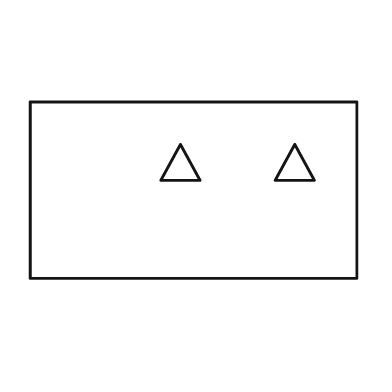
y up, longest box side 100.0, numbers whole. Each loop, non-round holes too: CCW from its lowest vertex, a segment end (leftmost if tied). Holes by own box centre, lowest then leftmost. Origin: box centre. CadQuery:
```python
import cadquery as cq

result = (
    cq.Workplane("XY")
    .moveTo(-50.0, -27.0)
    .lineTo(50.0, -27.0)
    .lineTo(50.0, 27.0)
    .lineTo(-50.0, 27.0)
    .close()
    .moveTo(-10.0, 3.0)
    .lineTo(2.0, 3.0)
    .lineTo(-4.0, 14.0)
    .close()
    .moveTo(25.0, 3.0)
    .lineTo(37.0, 3.0)
    .lineTo(31.0, 14.0)
    .close()
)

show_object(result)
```